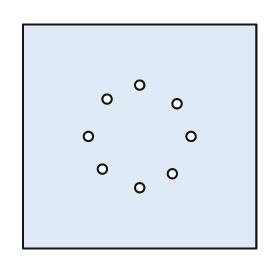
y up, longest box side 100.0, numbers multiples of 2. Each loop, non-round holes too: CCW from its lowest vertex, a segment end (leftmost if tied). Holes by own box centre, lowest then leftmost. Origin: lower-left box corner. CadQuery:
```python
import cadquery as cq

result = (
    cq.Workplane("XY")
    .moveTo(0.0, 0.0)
    .lineTo(100.0, 0.0)
    .lineTo(100.0, 96.0)
    .lineTo(0.0, 96.0)
    .close()
    .moveTo(50.0, 26.0)
    .circle(2.0)
    .moveTo(64.0, 32.0)
    .circle(2.0)
    .moveTo(34.0, 34.0)
    .circle(2.0)
    .moveTo(28.0, 48.0)
    .circle(2.0)
    .moveTo(72.0, 48.0)
    .circle(2.0)
    .moveTo(66.0, 62.0)
    .circle(2.0)
    .moveTo(36.0, 64.0)
    .circle(2.0)
    .moveTo(50.0, 70.0)
    .circle(2.0)
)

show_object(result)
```